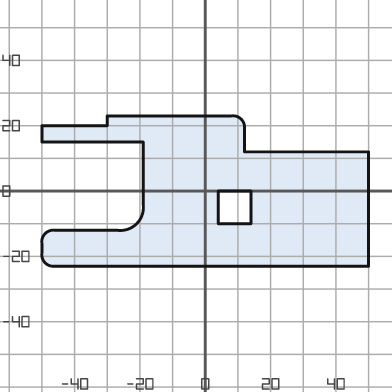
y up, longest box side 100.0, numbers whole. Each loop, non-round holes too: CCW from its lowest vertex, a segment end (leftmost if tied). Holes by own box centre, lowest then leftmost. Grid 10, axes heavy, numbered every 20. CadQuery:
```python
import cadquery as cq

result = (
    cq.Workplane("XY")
    .moveTo(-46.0, -23.0)
    .lineTo(50.0, -23.0)
    .lineTo(50.0, 12.0)
    .lineTo(12.0, 12.0)
    .lineTo(12.0, 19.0)
    .threePointArc((11.0, 22.0), (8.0, 23.0))
    .lineTo(-30.0, 23.0)
    .lineTo(-30.0, 20.0)
    .lineTo(-50.0, 20.0)
    .lineTo(-50.0, 15.0)
    .lineTo(-19.0, 15.0)
    .lineTo(-19.0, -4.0)
    .threePointArc((-21.0, -10.0), (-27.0, -12.0))
    .lineTo(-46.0, -12.0)
    .threePointArc((-49.0, -13.0), (-50.0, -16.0))
    .lineTo(-50.0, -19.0)
    .threePointArc((-49.0, -22.0), (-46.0, -23.0))
    .close()
    .moveTo(4.0, -10.0)
    .lineTo(14.0, -10.0)
    .lineTo(14.0, 0.0)
    .lineTo(4.0, 0.0)
    .close()
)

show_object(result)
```